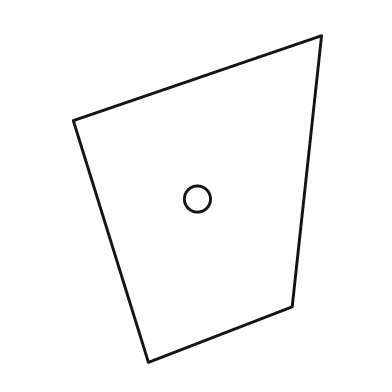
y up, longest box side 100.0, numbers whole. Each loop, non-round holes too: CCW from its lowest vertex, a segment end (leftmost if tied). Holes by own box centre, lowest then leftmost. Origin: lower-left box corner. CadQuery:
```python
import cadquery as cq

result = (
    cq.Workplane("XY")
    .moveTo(23.0, 0.0)
    .lineTo(67.0, 17.0)
    .lineTo(76.0, 100.0)
    .lineTo(0.0, 74.0)
    .close()
    .moveTo(38.0, 50.0)
    .circle(4.0)
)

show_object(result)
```